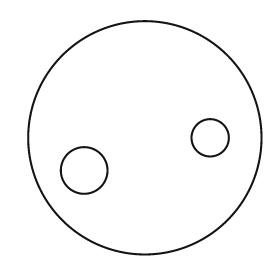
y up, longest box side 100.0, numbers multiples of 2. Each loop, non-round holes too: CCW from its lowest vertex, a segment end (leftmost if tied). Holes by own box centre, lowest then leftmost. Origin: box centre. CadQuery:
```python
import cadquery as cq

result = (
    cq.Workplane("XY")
    .moveTo(0.0, 0.0)
    .circle(50.0)
    .moveTo(-26.0, -14.0)
    .circle(10.0)
    .moveTo(28.0, 0.0)
    .circle(8.0)
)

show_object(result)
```